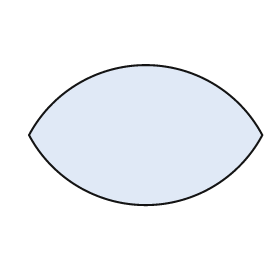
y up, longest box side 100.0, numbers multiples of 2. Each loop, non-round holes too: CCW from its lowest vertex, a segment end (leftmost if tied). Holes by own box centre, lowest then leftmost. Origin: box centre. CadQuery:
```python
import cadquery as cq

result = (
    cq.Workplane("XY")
    .moveTo(-50.0, 0.0)
    .threePointArc((0.0, -30.0), (50.0, 0.0))
    .threePointArc((0.0, 30.0), (-50.0, 0.0))
    .close()
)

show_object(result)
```